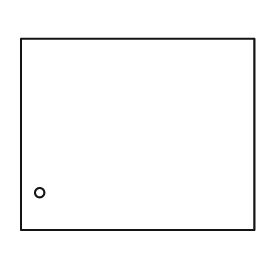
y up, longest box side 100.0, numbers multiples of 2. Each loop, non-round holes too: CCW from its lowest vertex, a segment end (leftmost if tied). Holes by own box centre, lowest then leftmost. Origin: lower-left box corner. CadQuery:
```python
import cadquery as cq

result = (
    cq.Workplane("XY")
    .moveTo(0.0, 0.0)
    .lineTo(100.0, 0.0)
    .lineTo(100.0, 82.0)
    .lineTo(0.0, 82.0)
    .close()
    .moveTo(8.0, 16.0)
    .circle(2.0)
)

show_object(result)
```